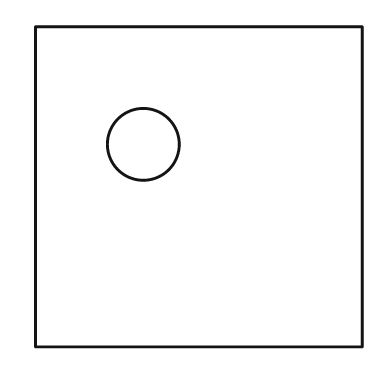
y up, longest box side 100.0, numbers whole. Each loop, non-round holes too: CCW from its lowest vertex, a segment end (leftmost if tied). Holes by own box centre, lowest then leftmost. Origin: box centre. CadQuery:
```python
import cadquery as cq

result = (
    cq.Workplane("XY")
    .moveTo(-50.0, -49.0)
    .lineTo(50.0, -49.0)
    .lineTo(50.0, 49.0)
    .lineTo(-50.0, 49.0)
    .close()
    .moveTo(-17.0, 13.0)
    .circle(11.0)
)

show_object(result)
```